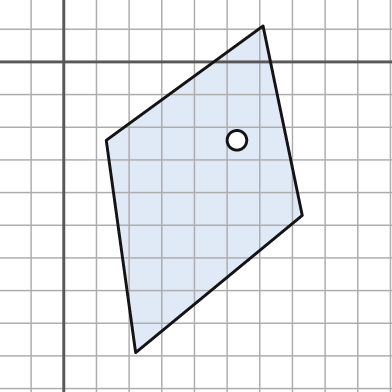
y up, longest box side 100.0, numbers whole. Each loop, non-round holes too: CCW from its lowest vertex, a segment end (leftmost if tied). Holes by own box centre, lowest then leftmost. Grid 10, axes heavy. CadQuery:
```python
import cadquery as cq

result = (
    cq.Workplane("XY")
    .moveTo(22.0, -89.0)
    .lineTo(73.0, -47.0)
    .lineTo(61.0, 11.0)
    .lineTo(13.0, -24.0)
    .close()
    .moveTo(53.0, -24.0)
    .circle(3.0)
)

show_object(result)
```